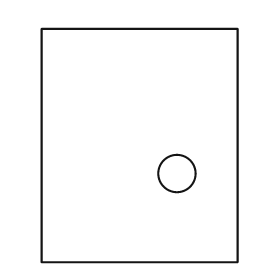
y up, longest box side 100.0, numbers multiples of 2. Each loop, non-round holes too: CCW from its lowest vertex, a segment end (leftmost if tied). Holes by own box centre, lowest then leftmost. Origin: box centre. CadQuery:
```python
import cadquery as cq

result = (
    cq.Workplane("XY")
    .moveTo(-42.0, -50.0)
    .lineTo(42.0, -50.0)
    .lineTo(42.0, 50.0)
    .lineTo(-42.0, 50.0)
    .close()
    .moveTo(16.0, -12.0)
    .circle(8.0)
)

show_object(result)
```